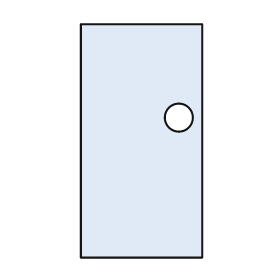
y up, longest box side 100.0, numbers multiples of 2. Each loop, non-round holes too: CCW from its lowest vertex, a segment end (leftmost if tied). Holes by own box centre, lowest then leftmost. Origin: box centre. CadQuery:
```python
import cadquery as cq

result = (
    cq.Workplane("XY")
    .moveTo(-26.0, -50.0)
    .lineTo(26.0, -50.0)
    .lineTo(26.0, 50.0)
    .lineTo(-26.0, 50.0)
    .close()
    .moveTo(16.0, 10.0)
    .circle(6.0)
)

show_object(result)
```